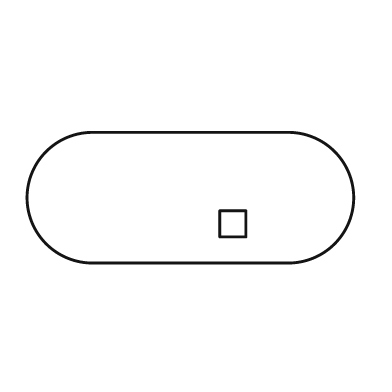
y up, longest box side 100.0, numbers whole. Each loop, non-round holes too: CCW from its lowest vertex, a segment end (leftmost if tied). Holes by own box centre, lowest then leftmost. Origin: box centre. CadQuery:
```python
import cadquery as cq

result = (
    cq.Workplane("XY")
    .moveTo(-30.0, -20.0)
    .lineTo(30.0, -20.0)
    .threePointArc((50.0, 0.0), (30.0, 20.0))
    .lineTo(-30.0, 20.0)
    .threePointArc((-50.0, 0.0), (-30.0, -20.0))
    .close()
    .moveTo(9.0, -12.0)
    .lineTo(17.0, -12.0)
    .lineTo(17.0, -4.0)
    .lineTo(9.0, -4.0)
    .close()
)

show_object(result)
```